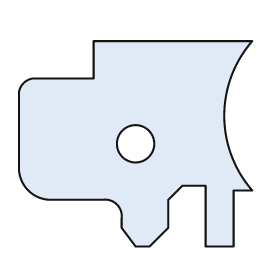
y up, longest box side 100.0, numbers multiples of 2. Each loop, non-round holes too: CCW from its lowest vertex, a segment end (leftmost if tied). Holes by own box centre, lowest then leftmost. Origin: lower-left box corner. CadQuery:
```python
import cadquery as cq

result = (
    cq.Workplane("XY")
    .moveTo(50.0, 0.0)
    .lineTo(56.0, 0.0)
    .lineTo(64.0, 8.0)
    .lineTo(64.0, 20.0)
    .lineTo(70.0, 26.0)
    .lineTo(80.0, 26.0)
    .lineTo(80.0, 0.0)
    .lineTo(92.0, 0.0)
    .lineTo(92.0, 24.0)
    .lineTo(100.0, 24.0)
    .threePointArc((88.0, 56.0), (100.0, 88.0))
    .lineTo(32.0, 88.0)
    .lineTo(32.0, 72.0)
    .lineTo(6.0, 72.0)
    .threePointArc((2.0, 70.0), (0.0, 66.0))
    .lineTo(0.0, 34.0)
    .threePointArc((4.0, 24.0), (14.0, 20.0))
    .lineTo(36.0, 20.0)
    .threePointArc((42.0, 18.0), (44.0, 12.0))
    .lineTo(44.0, 8.0)
    .close()
    .moveTo(50.0, 44.0)
    .circle(8.0)
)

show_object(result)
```